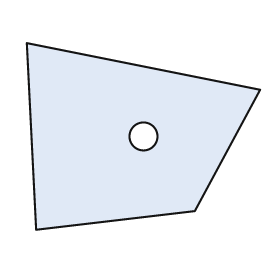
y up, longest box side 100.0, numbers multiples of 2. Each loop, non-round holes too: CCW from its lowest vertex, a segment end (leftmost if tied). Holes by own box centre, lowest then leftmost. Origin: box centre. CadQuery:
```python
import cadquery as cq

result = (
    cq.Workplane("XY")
    .moveTo(-46.0, -40.0)
    .lineTo(22.0, -32.0)
    .lineTo(50.0, 20.0)
    .lineTo(-50.0, 40.0)
    .close()
    .moveTo(0.0, 0.0)
    .circle(6.0)
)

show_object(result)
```